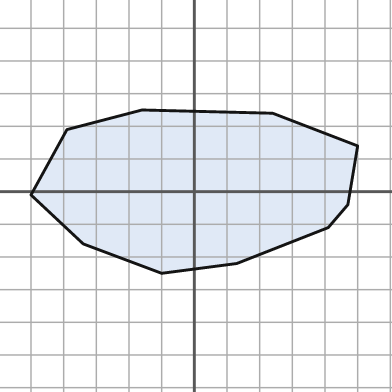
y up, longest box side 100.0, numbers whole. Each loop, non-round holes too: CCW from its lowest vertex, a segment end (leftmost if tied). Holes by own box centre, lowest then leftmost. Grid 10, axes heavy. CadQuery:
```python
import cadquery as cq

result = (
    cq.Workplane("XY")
    .moveTo(-10.0, -25.0)
    .lineTo(13.0, -22.0)
    .lineTo(41.0, -11.0)
    .lineTo(47.0, -4.0)
    .lineTo(50.0, 14.0)
    .lineTo(24.0, 24.0)
    .lineTo(-16.0, 25.0)
    .lineTo(-39.0, 19.0)
    .lineTo(-50.0, -1.0)
    .lineTo(-34.0, -16.0)
    .close()
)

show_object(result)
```